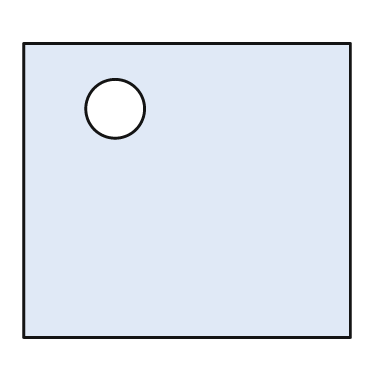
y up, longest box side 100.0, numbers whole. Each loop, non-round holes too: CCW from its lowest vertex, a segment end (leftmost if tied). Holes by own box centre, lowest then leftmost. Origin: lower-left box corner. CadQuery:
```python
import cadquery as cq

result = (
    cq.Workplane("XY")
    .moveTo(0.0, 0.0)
    .lineTo(100.0, 0.0)
    .lineTo(100.0, 90.0)
    .lineTo(0.0, 90.0)
    .close()
    .moveTo(28.0, 70.0)
    .circle(9.0)
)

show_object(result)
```